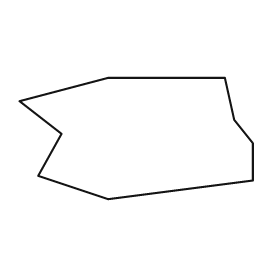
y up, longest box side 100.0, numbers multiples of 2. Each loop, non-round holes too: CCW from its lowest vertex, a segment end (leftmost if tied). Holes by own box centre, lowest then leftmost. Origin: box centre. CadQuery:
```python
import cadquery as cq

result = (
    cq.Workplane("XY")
    .moveTo(-12.0, -26.0)
    .lineTo(50.0, -18.0)
    .lineTo(50.0, -2.0)
    .lineTo(42.0, 8.0)
    .lineTo(38.0, 26.0)
    .lineTo(-12.0, 26.0)
    .lineTo(-50.0, 16.0)
    .lineTo(-32.0, 2.0)
    .lineTo(-42.0, -16.0)
    .close()
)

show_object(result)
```